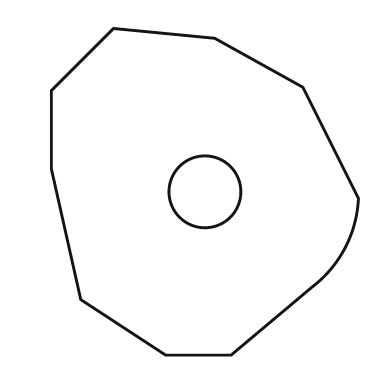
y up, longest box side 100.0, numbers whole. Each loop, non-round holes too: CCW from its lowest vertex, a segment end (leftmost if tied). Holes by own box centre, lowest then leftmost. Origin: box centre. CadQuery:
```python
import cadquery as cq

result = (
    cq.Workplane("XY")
    .moveTo(-12.0, -50.0)
    .lineTo(8.0, -50.0)
    .lineTo(33.0, -29.0)
    .threePointArc((43.0, -17.0), (47.0, -2.0))
    .lineTo(30.0, 32.0)
    .lineTo(3.0, 47.0)
    .lineTo(-28.0, 50.0)
    .lineTo(-47.0, 31.0)
    .lineTo(-47.0, 7.0)
    .lineTo(-38.0, -33.0)
    .close()
    .moveTo(0.0, 0.0)
    .circle(11.0)
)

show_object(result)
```